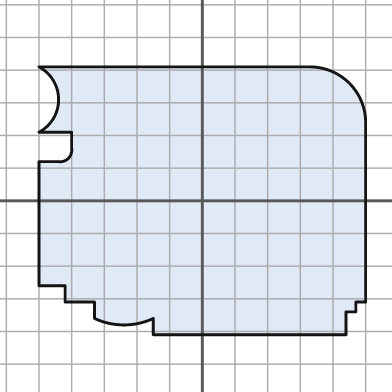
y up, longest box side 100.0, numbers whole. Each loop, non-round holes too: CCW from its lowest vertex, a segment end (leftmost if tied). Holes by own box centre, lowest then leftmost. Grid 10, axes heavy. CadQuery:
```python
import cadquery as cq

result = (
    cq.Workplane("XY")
    .moveTo(-15.0, -41.0)
    .lineTo(44.0, -41.0)
    .lineTo(44.0, -34.0)
    .lineTo(47.0, -34.0)
    .lineTo(47.0, -31.0)
    .lineTo(50.0, -31.0)
    .lineTo(50.0, 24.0)
    .threePointArc((45.0, 36.0), (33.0, 41.0))
    .lineTo(-50.0, 41.0)
    .threePointArc((-44.0, 31.0), (-50.0, 21.0))
    .lineTo(-40.0, 21.0)
    .lineTo(-40.0, 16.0)
    .threePointArc((-41.0, 13.0), (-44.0, 12.0))
    .lineTo(-50.0, 12.0)
    .lineTo(-50.0, -26.0)
    .lineTo(-42.0, -26.0)
    .lineTo(-42.0, -31.0)
    .lineTo(-33.0, -31.0)
    .lineTo(-33.0, -36.0)
    .threePointArc((-24.0, -38.0), (-15.0, -36.0))
    .close()
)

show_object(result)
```